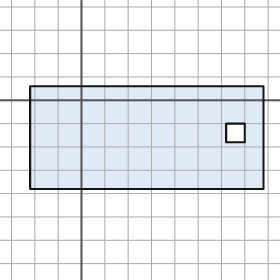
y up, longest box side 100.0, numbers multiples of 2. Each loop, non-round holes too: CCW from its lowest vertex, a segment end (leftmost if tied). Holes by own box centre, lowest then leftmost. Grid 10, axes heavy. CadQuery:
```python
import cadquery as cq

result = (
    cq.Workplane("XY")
    .moveTo(-22.0, -38.0)
    .lineTo(78.0, -38.0)
    .lineTo(78.0, 6.0)
    .lineTo(-22.0, 6.0)
    .close()
    .moveTo(62.0, -18.0)
    .lineTo(70.0, -18.0)
    .lineTo(70.0, -10.0)
    .lineTo(62.0, -10.0)
    .close()
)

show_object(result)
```